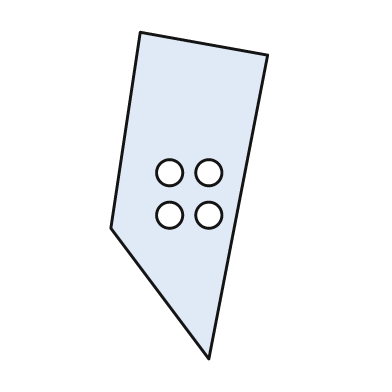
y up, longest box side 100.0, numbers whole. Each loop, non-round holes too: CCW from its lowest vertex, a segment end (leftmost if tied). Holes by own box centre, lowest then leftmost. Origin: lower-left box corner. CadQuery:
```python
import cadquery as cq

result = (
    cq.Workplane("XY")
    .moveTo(30.0, 0.0)
    .lineTo(48.0, 93.0)
    .lineTo(9.0, 100.0)
    .lineTo(0.0, 40.0)
    .close()
    .moveTo(18.0, 44.0)
    .circle(4.0)
    .moveTo(30.0, 44.0)
    .circle(4.0)
    .moveTo(18.0, 57.0)
    .circle(4.0)
    .moveTo(30.0, 57.0)
    .circle(4.0)
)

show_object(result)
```